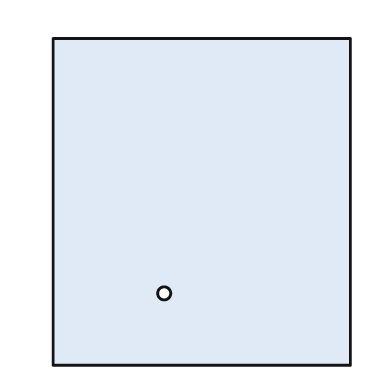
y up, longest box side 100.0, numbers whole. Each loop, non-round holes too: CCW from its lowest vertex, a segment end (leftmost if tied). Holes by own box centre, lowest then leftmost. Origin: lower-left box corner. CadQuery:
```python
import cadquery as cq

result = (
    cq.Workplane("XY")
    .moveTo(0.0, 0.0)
    .lineTo(91.0, 0.0)
    .lineTo(91.0, 100.0)
    .lineTo(0.0, 100.0)
    .close()
    .moveTo(34.0, 22.0)
    .circle(2.0)
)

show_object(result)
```